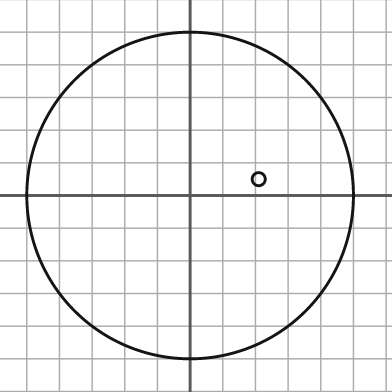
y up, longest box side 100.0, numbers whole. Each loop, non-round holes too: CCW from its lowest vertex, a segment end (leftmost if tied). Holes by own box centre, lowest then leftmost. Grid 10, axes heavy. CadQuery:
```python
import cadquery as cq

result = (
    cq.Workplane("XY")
    .moveTo(0.0, 0.0)
    .circle(50.0)
    .moveTo(21.0, 5.0)
    .circle(2.0)
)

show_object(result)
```